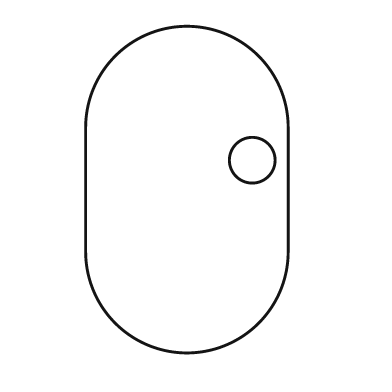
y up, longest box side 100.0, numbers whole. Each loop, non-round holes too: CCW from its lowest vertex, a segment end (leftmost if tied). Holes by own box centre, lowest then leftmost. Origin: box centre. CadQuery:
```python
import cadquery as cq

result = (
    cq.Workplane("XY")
    .moveTo(-31.0, -19.0)
    .threePointArc((0.0, -50.0), (31.0, -19.0))
    .lineTo(31.0, 19.0)
    .threePointArc((0.0, 50.0), (-31.0, 19.0))
    .close()
    .moveTo(20.0, 9.0)
    .circle(7.0)
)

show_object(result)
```